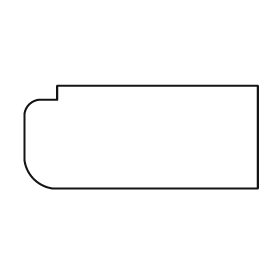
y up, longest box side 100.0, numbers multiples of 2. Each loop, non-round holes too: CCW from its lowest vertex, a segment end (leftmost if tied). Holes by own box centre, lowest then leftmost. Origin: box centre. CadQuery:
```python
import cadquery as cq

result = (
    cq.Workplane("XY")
    .moveTo(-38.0, -22.0)
    .lineTo(50.0, -22.0)
    .lineTo(50.0, 22.0)
    .lineTo(-36.0, 22.0)
    .lineTo(-36.0, 16.0)
    .lineTo(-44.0, 16.0)
    .threePointArc((-48.0, 14.0), (-50.0, 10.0))
    .lineTo(-50.0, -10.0)
    .threePointArc((-46.0, -18.0), (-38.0, -22.0))
    .close()
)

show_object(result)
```